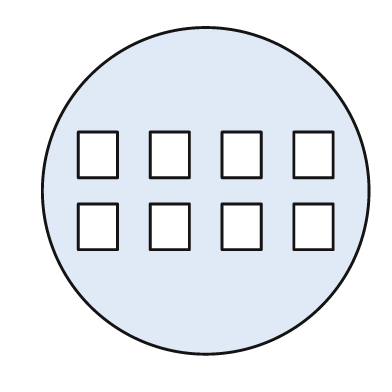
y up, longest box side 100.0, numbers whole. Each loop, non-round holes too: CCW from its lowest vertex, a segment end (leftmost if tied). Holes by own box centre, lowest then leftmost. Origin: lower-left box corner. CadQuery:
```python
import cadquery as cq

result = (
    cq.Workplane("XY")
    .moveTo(50.0, 50.0)
    .circle(50.0)
    .moveTo(11.0, 32.0)
    .lineTo(23.0, 32.0)
    .lineTo(23.0, 46.0)
    .lineTo(11.0, 46.0)
    .close()
    .moveTo(33.0, 32.0)
    .lineTo(45.0, 32.0)
    .lineTo(45.0, 46.0)
    .lineTo(33.0, 46.0)
    .close()
    .moveTo(55.0, 32.0)
    .lineTo(67.0, 32.0)
    .lineTo(67.0, 46.0)
    .lineTo(55.0, 46.0)
    .close()
    .moveTo(77.0, 32.0)
    .lineTo(89.0, 32.0)
    .lineTo(89.0, 46.0)
    .lineTo(77.0, 46.0)
    .close()
    .moveTo(11.0, 54.0)
    .lineTo(23.0, 54.0)
    .lineTo(23.0, 68.0)
    .lineTo(11.0, 68.0)
    .close()
    .moveTo(33.0, 54.0)
    .lineTo(45.0, 54.0)
    .lineTo(45.0, 68.0)
    .lineTo(33.0, 68.0)
    .close()
    .moveTo(55.0, 54.0)
    .lineTo(67.0, 54.0)
    .lineTo(67.0, 68.0)
    .lineTo(55.0, 68.0)
    .close()
    .moveTo(77.0, 54.0)
    .lineTo(89.0, 54.0)
    .lineTo(89.0, 68.0)
    .lineTo(77.0, 68.0)
    .close()
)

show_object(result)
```